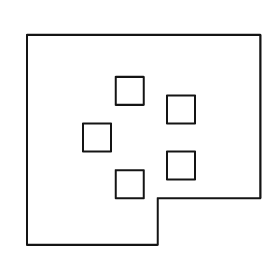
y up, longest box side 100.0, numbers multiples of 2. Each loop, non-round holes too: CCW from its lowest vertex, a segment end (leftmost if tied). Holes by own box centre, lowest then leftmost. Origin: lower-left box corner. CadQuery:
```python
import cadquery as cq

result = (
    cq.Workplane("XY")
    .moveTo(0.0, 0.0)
    .lineTo(56.0, 0.0)
    .lineTo(56.0, 20.0)
    .lineTo(100.0, 20.0)
    .lineTo(100.0, 90.0)
    .lineTo(0.0, 90.0)
    .close()
    .moveTo(38.0, 20.0)
    .lineTo(50.0, 20.0)
    .lineTo(50.0, 32.0)
    .lineTo(38.0, 32.0)
    .close()
    .moveTo(60.0, 28.0)
    .lineTo(72.0, 28.0)
    .lineTo(72.0, 40.0)
    .lineTo(60.0, 40.0)
    .close()
    .moveTo(24.0, 40.0)
    .lineTo(36.0, 40.0)
    .lineTo(36.0, 52.0)
    .lineTo(24.0, 52.0)
    .close()
    .moveTo(60.0, 52.0)
    .lineTo(72.0, 52.0)
    .lineTo(72.0, 64.0)
    .lineTo(60.0, 64.0)
    .close()
    .moveTo(38.0, 60.0)
    .lineTo(50.0, 60.0)
    .lineTo(50.0, 72.0)
    .lineTo(38.0, 72.0)
    .close()
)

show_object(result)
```